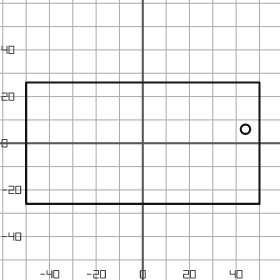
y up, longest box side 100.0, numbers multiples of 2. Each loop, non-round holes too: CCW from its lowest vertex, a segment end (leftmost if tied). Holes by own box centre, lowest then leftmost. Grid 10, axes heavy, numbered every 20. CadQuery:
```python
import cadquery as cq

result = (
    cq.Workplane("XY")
    .moveTo(-50.0, -26.0)
    .lineTo(50.0, -26.0)
    .lineTo(50.0, 26.0)
    .lineTo(-50.0, 26.0)
    .close()
    .moveTo(44.0, 6.0)
    .circle(2.0)
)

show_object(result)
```